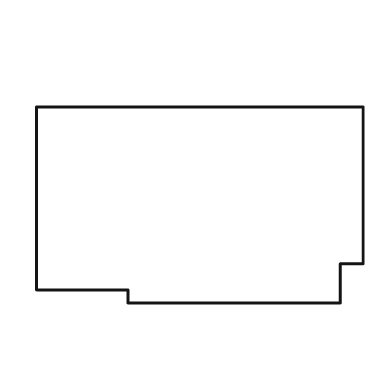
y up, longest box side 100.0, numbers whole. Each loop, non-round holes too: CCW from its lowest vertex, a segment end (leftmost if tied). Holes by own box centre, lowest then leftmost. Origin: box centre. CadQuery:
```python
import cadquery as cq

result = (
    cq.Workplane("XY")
    .moveTo(-22.0, -30.0)
    .lineTo(43.0, -30.0)
    .lineTo(43.0, -18.0)
    .lineTo(50.0, -18.0)
    .lineTo(50.0, 30.0)
    .lineTo(-50.0, 30.0)
    .lineTo(-50.0, -26.0)
    .lineTo(-22.0, -26.0)
    .close()
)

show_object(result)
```